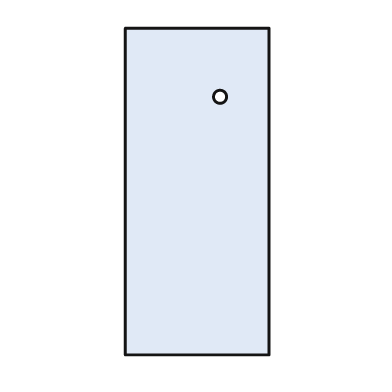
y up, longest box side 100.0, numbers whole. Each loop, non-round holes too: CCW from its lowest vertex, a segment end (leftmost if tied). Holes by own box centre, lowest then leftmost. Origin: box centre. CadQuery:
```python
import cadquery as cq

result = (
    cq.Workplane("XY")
    .moveTo(-22.0, -50.0)
    .lineTo(22.0, -50.0)
    .lineTo(22.0, 50.0)
    .lineTo(-22.0, 50.0)
    .close()
    .moveTo(7.0, 29.0)
    .circle(2.0)
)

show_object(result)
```